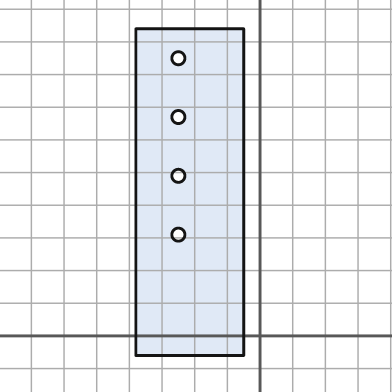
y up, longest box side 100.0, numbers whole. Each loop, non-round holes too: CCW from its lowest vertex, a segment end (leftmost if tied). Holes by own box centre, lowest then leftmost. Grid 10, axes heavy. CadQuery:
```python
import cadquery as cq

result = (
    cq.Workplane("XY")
    .moveTo(-38.0, -6.0)
    .lineTo(-5.0, -6.0)
    .lineTo(-5.0, 94.0)
    .lineTo(-38.0, 94.0)
    .close()
    .moveTo(-25.0, 31.0)
    .circle(2.0)
    .moveTo(-25.0, 49.0)
    .circle(2.0)
    .moveTo(-25.0, 67.0)
    .circle(2.0)
    .moveTo(-25.0, 85.0)
    .circle(2.0)
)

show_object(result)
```